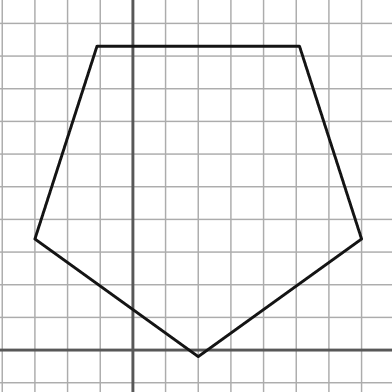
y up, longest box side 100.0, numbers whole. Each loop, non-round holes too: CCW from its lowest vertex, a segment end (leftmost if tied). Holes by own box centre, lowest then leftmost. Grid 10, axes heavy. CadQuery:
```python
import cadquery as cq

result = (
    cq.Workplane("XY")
    .moveTo(20.0, -2.0)
    .lineTo(70.0, 34.0)
    .lineTo(51.0, 93.0)
    .lineTo(-11.0, 93.0)
    .lineTo(-30.0, 34.0)
    .close()
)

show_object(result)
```